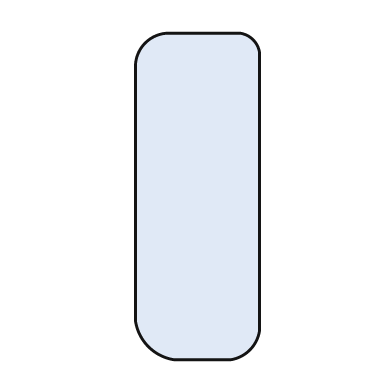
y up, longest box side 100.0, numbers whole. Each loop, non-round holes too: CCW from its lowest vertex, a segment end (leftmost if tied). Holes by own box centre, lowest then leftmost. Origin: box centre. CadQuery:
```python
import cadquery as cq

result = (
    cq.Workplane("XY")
    .moveTo(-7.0, -50.0)
    .lineTo(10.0, -50.0)
    .threePointArc((16.0, -47.0), (19.0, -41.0))
    .lineTo(19.0, 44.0)
    .threePointArc((17.0, 48.0), (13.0, 50.0))
    .lineTo(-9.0, 50.0)
    .threePointArc((-16.0, 47.0), (-19.0, 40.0))
    .lineTo(-19.0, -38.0)
    .threePointArc((-15.0, -46.0), (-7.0, -50.0))
    .close()
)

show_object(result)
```